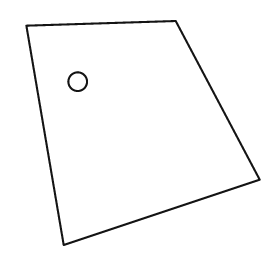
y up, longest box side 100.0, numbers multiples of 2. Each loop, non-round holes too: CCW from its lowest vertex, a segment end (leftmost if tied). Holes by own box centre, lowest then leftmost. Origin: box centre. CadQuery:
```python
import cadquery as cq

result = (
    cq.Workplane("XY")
    .moveTo(-34.0, -48.0)
    .lineTo(50.0, -20.0)
    .lineTo(14.0, 48.0)
    .lineTo(-50.0, 46.0)
    .close()
    .moveTo(-28.0, 22.0)
    .circle(4.0)
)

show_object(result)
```